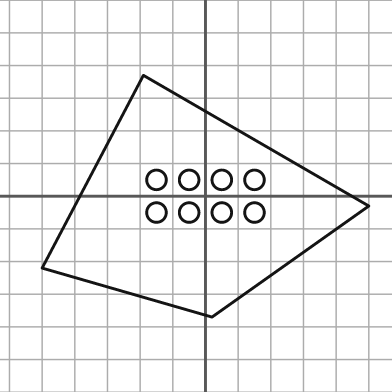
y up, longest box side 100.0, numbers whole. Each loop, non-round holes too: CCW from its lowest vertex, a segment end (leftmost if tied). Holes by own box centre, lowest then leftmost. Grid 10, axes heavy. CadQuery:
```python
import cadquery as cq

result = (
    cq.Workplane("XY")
    .moveTo(2.0, -37.0)
    .lineTo(50.0, -3.0)
    .lineTo(-19.0, 37.0)
    .lineTo(-50.0, -22.0)
    .close()
    .moveTo(-15.0, -5.0)
    .circle(3.0)
    .moveTo(-5.0, -5.0)
    .circle(3.0)
    .moveTo(5.0, -5.0)
    .circle(3.0)
    .moveTo(15.0, -5.0)
    .circle(3.0)
    .moveTo(-15.0, 5.0)
    .circle(3.0)
    .moveTo(-5.0, 5.0)
    .circle(3.0)
    .moveTo(5.0, 5.0)
    .circle(3.0)
    .moveTo(15.0, 5.0)
    .circle(3.0)
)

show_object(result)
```